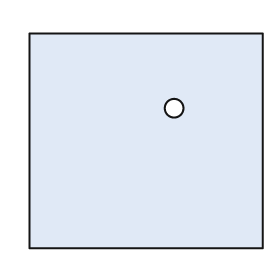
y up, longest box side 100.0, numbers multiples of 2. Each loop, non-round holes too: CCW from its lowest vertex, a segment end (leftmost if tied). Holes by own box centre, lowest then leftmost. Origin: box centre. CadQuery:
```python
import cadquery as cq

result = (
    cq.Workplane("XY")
    .moveTo(-50.0, -46.0)
    .lineTo(50.0, -46.0)
    .lineTo(50.0, 46.0)
    .lineTo(-50.0, 46.0)
    .close()
    .moveTo(12.0, 14.0)
    .circle(4.0)
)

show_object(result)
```